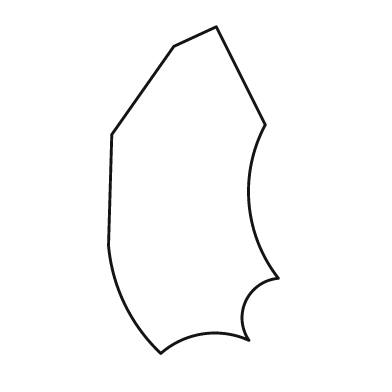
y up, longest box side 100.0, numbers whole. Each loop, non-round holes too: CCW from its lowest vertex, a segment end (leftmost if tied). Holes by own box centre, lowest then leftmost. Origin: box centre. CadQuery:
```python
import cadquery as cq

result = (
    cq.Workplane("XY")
    .moveTo(-10.0, -50.0)
    .threePointArc((3.0, -44.0), (17.0, -46.0))
    .threePointArc((16.0, -34.0), (26.0, -27.0))
    .threePointArc((17.0, -4.0), (22.0, 20.0))
    .lineTo(7.0, 50.0)
    .lineTo(-6.0, 44.0)
    .lineTo(-25.0, 17.0)
    .lineTo(-26.0, -17.0)
    .threePointArc((-21.0, -35.0), (-10.0, -50.0))
    .close()
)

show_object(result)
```